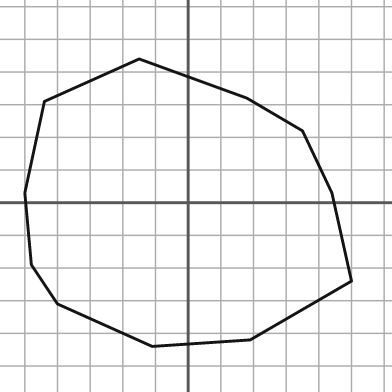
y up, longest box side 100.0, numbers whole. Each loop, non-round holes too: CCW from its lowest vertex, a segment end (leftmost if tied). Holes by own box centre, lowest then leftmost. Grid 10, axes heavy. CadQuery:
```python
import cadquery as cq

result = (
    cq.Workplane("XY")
    .moveTo(-11.0, -44.0)
    .lineTo(19.0, -42.0)
    .lineTo(50.0, -24.0)
    .lineTo(44.0, 3.0)
    .lineTo(35.0, 22.0)
    .lineTo(18.0, 32.0)
    .lineTo(-15.0, 44.0)
    .lineTo(-44.0, 31.0)
    .lineTo(-50.0, 3.0)
    .lineTo(-48.0, -19.0)
    .lineTo(-40.0, -31.0)
    .close()
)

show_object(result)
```